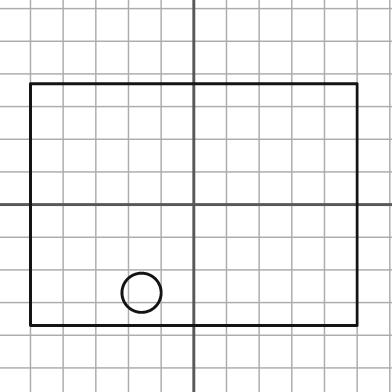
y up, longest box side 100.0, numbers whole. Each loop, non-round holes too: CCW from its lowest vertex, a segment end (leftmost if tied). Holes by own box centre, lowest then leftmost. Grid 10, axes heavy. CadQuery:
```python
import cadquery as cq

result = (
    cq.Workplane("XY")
    .moveTo(-50.0, -37.0)
    .lineTo(50.0, -37.0)
    .lineTo(50.0, 37.0)
    .lineTo(-50.0, 37.0)
    .close()
    .moveTo(-16.0, -27.0)
    .circle(6.0)
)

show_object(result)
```